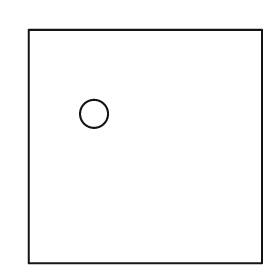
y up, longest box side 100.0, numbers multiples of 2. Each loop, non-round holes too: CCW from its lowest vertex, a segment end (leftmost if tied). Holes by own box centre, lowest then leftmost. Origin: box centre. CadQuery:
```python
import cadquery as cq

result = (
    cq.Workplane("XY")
    .moveTo(-50.0, -50.0)
    .lineTo(50.0, -50.0)
    .lineTo(50.0, 50.0)
    .lineTo(-50.0, 50.0)
    .close()
    .moveTo(-22.0, 14.0)
    .circle(6.0)
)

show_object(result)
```